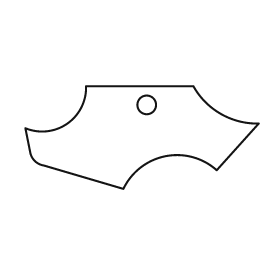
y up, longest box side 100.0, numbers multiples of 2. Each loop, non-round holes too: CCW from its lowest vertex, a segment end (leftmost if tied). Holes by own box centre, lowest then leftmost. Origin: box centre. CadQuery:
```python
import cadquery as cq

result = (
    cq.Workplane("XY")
    .moveTo(-8.0, -22.0)
    .threePointArc((10.0, -8.0), (32.0, -14.0))
    .lineTo(50.0, 6.0)
    .threePointArc((34.0, 10.0), (22.0, 22.0))
    .lineTo(-24.0, 22.0)
    .threePointArc((-32.0, 6.0), (-50.0, 4.0))
    .lineTo(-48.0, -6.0)
    .threePointArc((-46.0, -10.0), (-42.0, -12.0))
    .close()
    .moveTo(2.0, 14.0)
    .circle(4.0)
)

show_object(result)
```